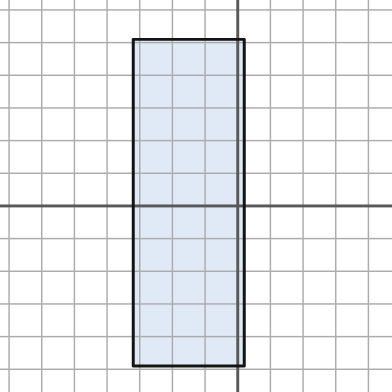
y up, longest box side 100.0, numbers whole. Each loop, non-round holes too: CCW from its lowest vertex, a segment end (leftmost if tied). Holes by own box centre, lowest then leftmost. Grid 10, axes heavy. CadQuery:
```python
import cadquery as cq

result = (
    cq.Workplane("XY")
    .moveTo(-32.0, -49.0)
    .lineTo(2.0, -49.0)
    .lineTo(2.0, 51.0)
    .lineTo(-32.0, 51.0)
    .close()
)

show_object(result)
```